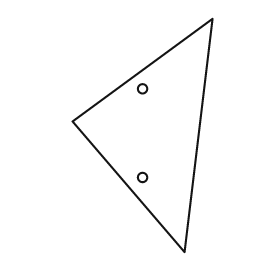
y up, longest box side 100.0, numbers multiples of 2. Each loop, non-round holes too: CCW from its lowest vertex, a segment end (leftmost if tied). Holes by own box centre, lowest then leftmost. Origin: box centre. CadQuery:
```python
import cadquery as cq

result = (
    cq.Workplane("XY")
    .moveTo(18.0, -50.0)
    .lineTo(30.0, 50.0)
    .lineTo(-30.0, 6.0)
    .close()
    .moveTo(0.0, -18.0)
    .circle(2.0)
    .moveTo(0.0, 20.0)
    .circle(2.0)
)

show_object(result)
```